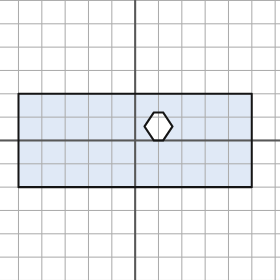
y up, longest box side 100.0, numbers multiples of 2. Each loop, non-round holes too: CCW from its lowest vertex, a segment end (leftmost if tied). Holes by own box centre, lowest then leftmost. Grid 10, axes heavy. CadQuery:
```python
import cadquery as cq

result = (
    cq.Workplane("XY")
    .moveTo(-50.0, -20.0)
    .lineTo(50.0, -20.0)
    .lineTo(50.0, 20.0)
    .lineTo(-50.0, 20.0)
    .close()
    .moveTo(8.0, 0.0)
    .lineTo(12.0, 0.0)
    .lineTo(16.0, 6.0)
    .lineTo(12.0, 12.0)
    .lineTo(8.0, 12.0)
    .lineTo(4.0, 6.0)
    .close()
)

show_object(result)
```